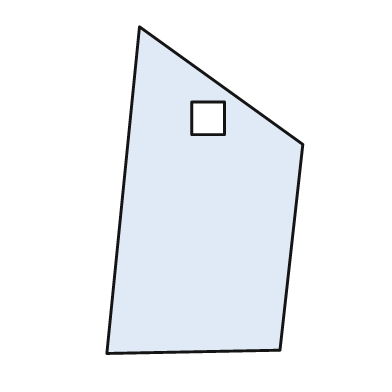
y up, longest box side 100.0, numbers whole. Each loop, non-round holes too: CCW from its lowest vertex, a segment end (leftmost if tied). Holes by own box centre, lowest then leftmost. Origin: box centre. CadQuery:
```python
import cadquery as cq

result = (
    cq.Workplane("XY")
    .moveTo(-30.0, -50.0)
    .lineTo(23.0, -49.0)
    .lineTo(30.0, 14.0)
    .lineTo(-20.0, 50.0)
    .close()
    .moveTo(-4.0, 17.0)
    .lineTo(6.0, 17.0)
    .lineTo(6.0, 27.0)
    .lineTo(-4.0, 27.0)
    .close()
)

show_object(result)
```